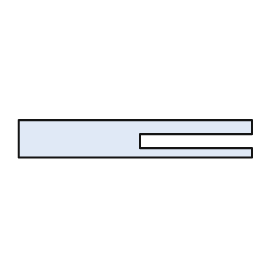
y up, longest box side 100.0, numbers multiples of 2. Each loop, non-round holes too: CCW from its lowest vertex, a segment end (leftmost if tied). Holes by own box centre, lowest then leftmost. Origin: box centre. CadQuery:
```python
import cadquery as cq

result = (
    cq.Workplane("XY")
    .moveTo(-50.0, -8.0)
    .lineTo(50.0, -8.0)
    .lineTo(50.0, -4.0)
    .lineTo(2.0, -4.0)
    .lineTo(2.0, 2.0)
    .lineTo(50.0, 2.0)
    .lineTo(50.0, 8.0)
    .lineTo(-50.0, 8.0)
    .close()
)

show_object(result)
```